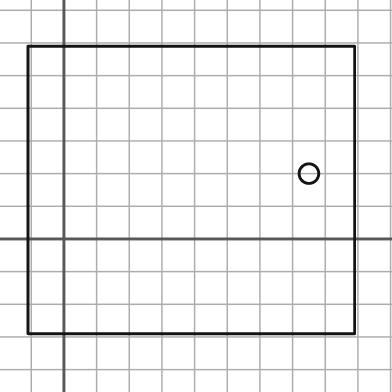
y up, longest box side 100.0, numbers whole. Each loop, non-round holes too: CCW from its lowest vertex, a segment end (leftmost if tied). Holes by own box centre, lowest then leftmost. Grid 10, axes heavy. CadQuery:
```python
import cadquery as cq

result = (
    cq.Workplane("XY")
    .moveTo(-11.0, -29.0)
    .lineTo(89.0, -29.0)
    .lineTo(89.0, 59.0)
    .lineTo(-11.0, 59.0)
    .close()
    .moveTo(75.0, 20.0)
    .circle(3.0)
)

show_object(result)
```